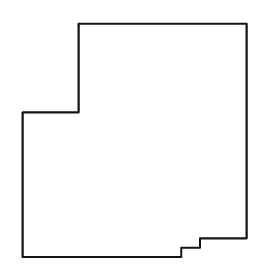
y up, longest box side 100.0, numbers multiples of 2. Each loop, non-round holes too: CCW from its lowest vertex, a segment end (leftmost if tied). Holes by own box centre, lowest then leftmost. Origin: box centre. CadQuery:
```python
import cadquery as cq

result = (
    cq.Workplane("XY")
    .moveTo(-48.0, -50.0)
    .lineTo(20.0, -50.0)
    .lineTo(20.0, -46.0)
    .lineTo(28.0, -46.0)
    .lineTo(28.0, -42.0)
    .lineTo(48.0, -42.0)
    .lineTo(48.0, 50.0)
    .lineTo(-24.0, 50.0)
    .lineTo(-24.0, 12.0)
    .lineTo(-48.0, 12.0)
    .close()
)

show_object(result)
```